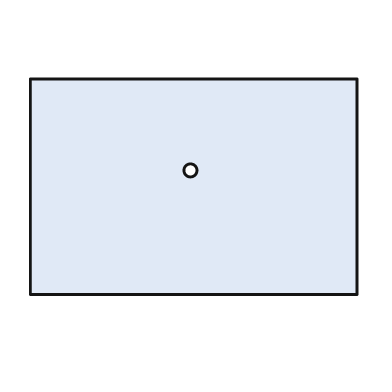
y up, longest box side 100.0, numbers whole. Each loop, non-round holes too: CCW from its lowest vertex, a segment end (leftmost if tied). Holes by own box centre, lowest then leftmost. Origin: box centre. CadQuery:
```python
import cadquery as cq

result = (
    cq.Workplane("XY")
    .moveTo(-50.0, -33.0)
    .lineTo(50.0, -33.0)
    .lineTo(50.0, 33.0)
    .lineTo(-50.0, 33.0)
    .close()
    .moveTo(-1.0, 5.0)
    .circle(2.0)
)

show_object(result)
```